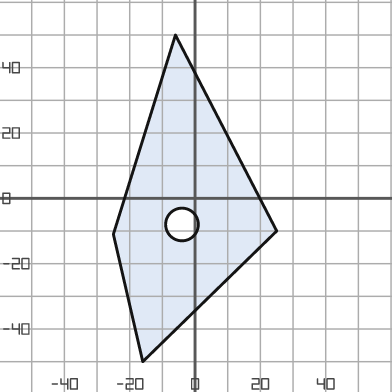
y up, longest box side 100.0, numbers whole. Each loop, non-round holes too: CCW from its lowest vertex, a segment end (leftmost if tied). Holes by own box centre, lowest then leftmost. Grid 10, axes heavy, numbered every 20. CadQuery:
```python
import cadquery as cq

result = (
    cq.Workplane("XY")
    .moveTo(-16.0, -50.0)
    .lineTo(25.0, -10.0)
    .lineTo(-6.0, 50.0)
    .lineTo(-25.0, -11.0)
    .close()
    .moveTo(-4.0, -8.0)
    .circle(5.0)
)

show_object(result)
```